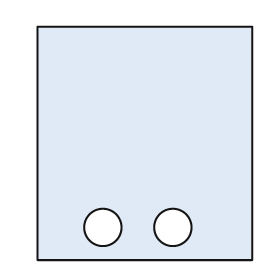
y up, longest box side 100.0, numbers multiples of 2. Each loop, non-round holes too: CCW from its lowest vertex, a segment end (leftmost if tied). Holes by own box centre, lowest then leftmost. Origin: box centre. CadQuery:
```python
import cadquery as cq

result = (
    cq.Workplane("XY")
    .moveTo(-46.0, -50.0)
    .lineTo(46.0, -50.0)
    .lineTo(46.0, 50.0)
    .lineTo(-46.0, 50.0)
    .close()
    .moveTo(-18.0, -36.0)
    .circle(8.0)
    .moveTo(12.0, -36.0)
    .circle(8.0)
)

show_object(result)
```